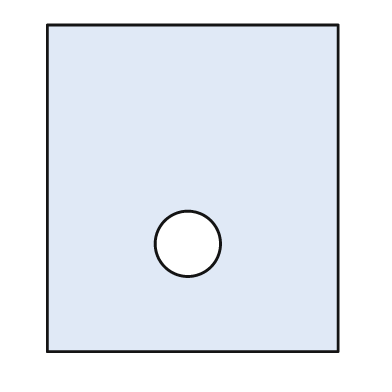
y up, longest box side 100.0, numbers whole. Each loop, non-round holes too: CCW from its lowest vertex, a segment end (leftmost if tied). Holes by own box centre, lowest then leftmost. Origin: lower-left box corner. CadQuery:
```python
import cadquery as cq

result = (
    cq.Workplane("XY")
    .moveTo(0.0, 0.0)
    .lineTo(89.0, 0.0)
    .lineTo(89.0, 100.0)
    .lineTo(0.0, 100.0)
    .close()
    .moveTo(43.0, 33.0)
    .circle(10.0)
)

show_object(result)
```